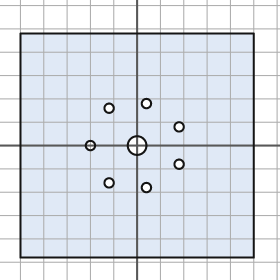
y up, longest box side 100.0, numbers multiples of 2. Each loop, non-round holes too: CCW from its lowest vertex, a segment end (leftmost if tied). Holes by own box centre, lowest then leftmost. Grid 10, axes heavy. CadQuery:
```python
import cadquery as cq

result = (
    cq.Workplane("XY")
    .moveTo(-50.0, -48.0)
    .lineTo(50.0, -48.0)
    .lineTo(50.0, 48.0)
    .lineTo(-50.0, 48.0)
    .close()
    .moveTo(4.0, -18.0)
    .circle(2.0)
    .moveTo(-12.0, -16.0)
    .circle(2.0)
    .moveTo(18.0, -8.0)
    .circle(2.0)
    .moveTo(-20.0, 0.0)
    .circle(2.0)
    .moveTo(0.0, 0.0)
    .circle(4.0)
    .moveTo(18.0, 8.0)
    .circle(2.0)
    .moveTo(-12.0, 16.0)
    .circle(2.0)
    .moveTo(4.0, 18.0)
    .circle(2.0)
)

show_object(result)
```